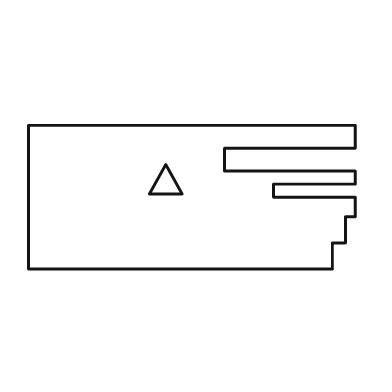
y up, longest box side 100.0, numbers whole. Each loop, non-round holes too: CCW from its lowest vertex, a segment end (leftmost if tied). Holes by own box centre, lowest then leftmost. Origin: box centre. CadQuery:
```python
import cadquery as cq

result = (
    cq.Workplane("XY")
    .moveTo(-50.0, -22.0)
    .lineTo(43.0, -22.0)
    .lineTo(43.0, -14.0)
    .lineTo(47.0, -14.0)
    .lineTo(47.0, -6.0)
    .lineTo(50.0, -6.0)
    .lineTo(50.0, 0.0)
    .lineTo(25.0, 0.0)
    .lineTo(25.0, 4.0)
    .lineTo(50.0, 4.0)
    .lineTo(50.0, 8.0)
    .lineTo(10.0, 8.0)
    .lineTo(10.0, 15.0)
    .lineTo(50.0, 15.0)
    .lineTo(50.0, 22.0)
    .lineTo(-50.0, 22.0)
    .close()
    .moveTo(-13.0, 1.0)
    .lineTo(-3.0, 1.0)
    .lineTo(-8.0, 10.0)
    .close()
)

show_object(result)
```